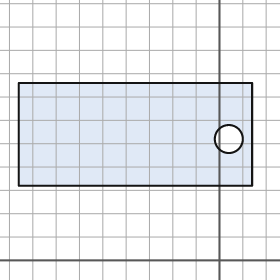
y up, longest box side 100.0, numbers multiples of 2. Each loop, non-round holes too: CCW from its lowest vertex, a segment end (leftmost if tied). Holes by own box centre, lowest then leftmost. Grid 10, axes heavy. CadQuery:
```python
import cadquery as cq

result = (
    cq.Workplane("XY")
    .moveTo(-86.0, 32.0)
    .lineTo(14.0, 32.0)
    .lineTo(14.0, 76.0)
    .lineTo(-86.0, 76.0)
    .close()
    .moveTo(4.0, 52.0)
    .circle(6.0)
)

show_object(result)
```